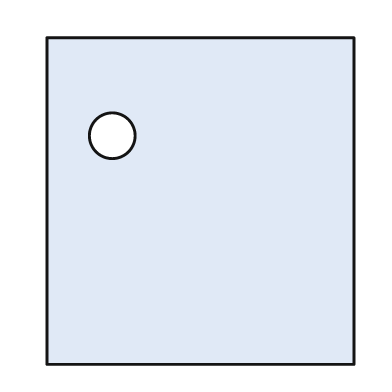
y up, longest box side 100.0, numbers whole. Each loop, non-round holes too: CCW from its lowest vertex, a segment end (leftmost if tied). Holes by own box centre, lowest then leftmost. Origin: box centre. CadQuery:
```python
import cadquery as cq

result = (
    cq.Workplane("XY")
    .moveTo(-47.0, -50.0)
    .lineTo(47.0, -50.0)
    .lineTo(47.0, 50.0)
    .lineTo(-47.0, 50.0)
    .close()
    .moveTo(-27.0, 20.0)
    .circle(7.0)
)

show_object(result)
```